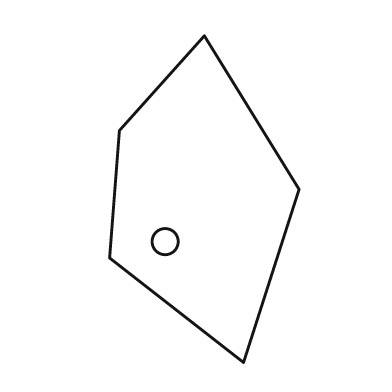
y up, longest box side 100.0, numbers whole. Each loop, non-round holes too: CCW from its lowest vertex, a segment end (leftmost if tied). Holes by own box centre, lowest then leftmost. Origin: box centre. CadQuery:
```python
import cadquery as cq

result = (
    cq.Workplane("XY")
    .moveTo(12.0, -50.0)
    .lineTo(29.0, 3.0)
    .lineTo(0.0, 50.0)
    .lineTo(-26.0, 21.0)
    .lineTo(-29.0, -18.0)
    .close()
    .moveTo(-12.0, -13.0)
    .circle(4.0)
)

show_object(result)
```